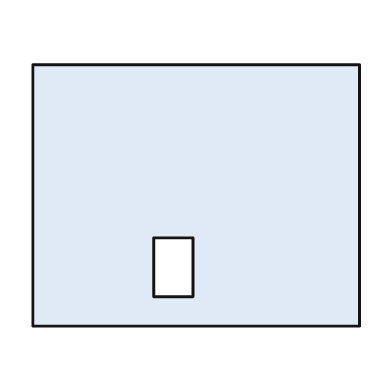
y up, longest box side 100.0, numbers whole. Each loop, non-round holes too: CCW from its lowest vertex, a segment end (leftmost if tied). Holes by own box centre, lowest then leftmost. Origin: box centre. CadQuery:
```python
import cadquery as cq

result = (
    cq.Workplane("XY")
    .moveTo(-50.0, -40.0)
    .lineTo(50.0, -40.0)
    .lineTo(50.0, 40.0)
    .lineTo(-50.0, 40.0)
    .close()
    .moveTo(-13.0, -31.0)
    .lineTo(-1.0, -31.0)
    .lineTo(-1.0, -13.0)
    .lineTo(-13.0, -13.0)
    .close()
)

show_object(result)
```